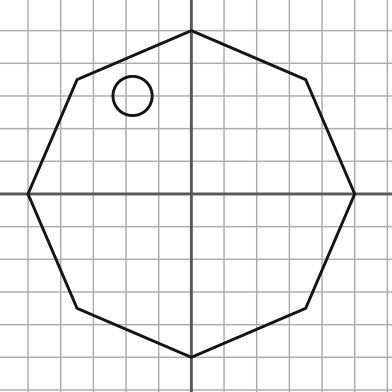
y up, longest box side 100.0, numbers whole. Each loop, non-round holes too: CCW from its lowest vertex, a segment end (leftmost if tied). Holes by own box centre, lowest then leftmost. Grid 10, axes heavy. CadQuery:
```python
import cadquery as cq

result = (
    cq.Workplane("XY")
    .moveTo(0.0, -50.0)
    .lineTo(35.0, -35.0)
    .lineTo(50.0, 0.0)
    .lineTo(35.0, 35.0)
    .lineTo(0.0, 50.0)
    .lineTo(-35.0, 35.0)
    .lineTo(-50.0, 0.0)
    .lineTo(-35.0, -35.0)
    .close()
    .moveTo(-18.0, 30.0)
    .circle(6.0)
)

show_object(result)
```